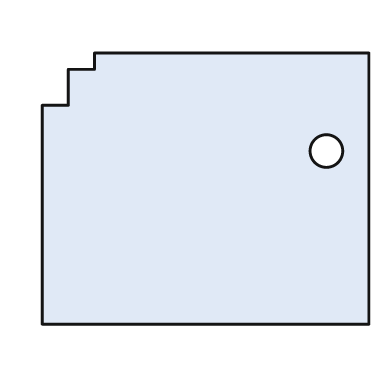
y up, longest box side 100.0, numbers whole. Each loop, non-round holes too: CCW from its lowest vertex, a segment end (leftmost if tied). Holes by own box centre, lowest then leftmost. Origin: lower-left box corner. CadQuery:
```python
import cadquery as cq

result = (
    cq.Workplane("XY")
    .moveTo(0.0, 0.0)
    .lineTo(100.0, 0.0)
    .lineTo(100.0, 83.0)
    .lineTo(16.0, 83.0)
    .lineTo(16.0, 78.0)
    .lineTo(8.0, 78.0)
    .lineTo(8.0, 67.0)
    .lineTo(0.0, 67.0)
    .close()
    .moveTo(87.0, 53.0)
    .circle(5.0)
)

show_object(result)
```